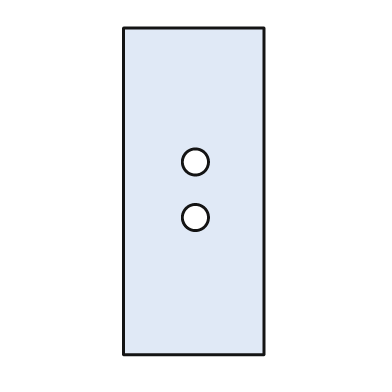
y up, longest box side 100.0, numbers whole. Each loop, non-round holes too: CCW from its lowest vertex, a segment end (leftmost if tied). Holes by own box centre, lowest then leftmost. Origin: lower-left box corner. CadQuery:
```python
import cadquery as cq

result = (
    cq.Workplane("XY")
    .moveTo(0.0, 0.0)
    .lineTo(43.0, 0.0)
    .lineTo(43.0, 100.0)
    .lineTo(0.0, 100.0)
    .close()
    .moveTo(22.0, 42.0)
    .circle(4.0)
    .moveTo(22.0, 59.0)
    .circle(4.0)
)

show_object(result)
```